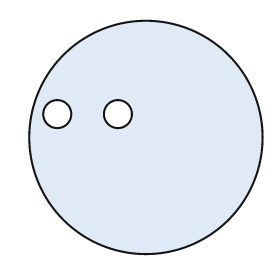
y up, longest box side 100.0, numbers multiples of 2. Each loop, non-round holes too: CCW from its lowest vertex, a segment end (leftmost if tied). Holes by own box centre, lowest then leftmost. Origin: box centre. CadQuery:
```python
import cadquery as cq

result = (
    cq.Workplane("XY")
    .moveTo(0.0, 0.0)
    .circle(50.0)
    .moveTo(-38.0, 10.0)
    .circle(6.0)
    .moveTo(-12.0, 10.0)
    .circle(6.0)
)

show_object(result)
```